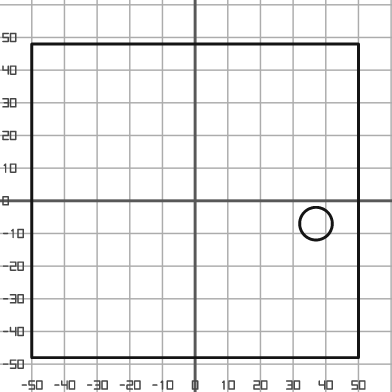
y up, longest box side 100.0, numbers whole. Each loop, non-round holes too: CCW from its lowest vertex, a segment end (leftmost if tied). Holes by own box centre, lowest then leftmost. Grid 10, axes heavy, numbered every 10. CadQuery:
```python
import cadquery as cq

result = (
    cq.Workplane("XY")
    .moveTo(-50.0, -48.0)
    .lineTo(50.0, -48.0)
    .lineTo(50.0, 48.0)
    .lineTo(-50.0, 48.0)
    .close()
    .moveTo(37.0, -7.0)
    .circle(5.0)
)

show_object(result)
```